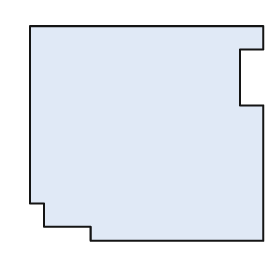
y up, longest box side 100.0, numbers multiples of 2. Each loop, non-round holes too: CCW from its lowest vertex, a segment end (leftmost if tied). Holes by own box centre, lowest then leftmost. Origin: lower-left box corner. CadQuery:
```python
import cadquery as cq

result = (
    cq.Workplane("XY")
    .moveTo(26.0, 0.0)
    .lineTo(100.0, 0.0)
    .lineTo(100.0, 58.0)
    .lineTo(90.0, 58.0)
    .lineTo(90.0, 82.0)
    .lineTo(100.0, 82.0)
    .lineTo(100.0, 92.0)
    .lineTo(0.0, 92.0)
    .lineTo(0.0, 16.0)
    .lineTo(6.0, 16.0)
    .lineTo(6.0, 6.0)
    .lineTo(26.0, 6.0)
    .close()
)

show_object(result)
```